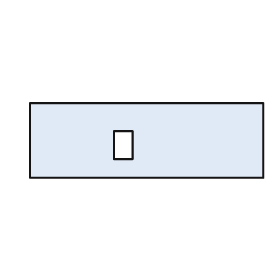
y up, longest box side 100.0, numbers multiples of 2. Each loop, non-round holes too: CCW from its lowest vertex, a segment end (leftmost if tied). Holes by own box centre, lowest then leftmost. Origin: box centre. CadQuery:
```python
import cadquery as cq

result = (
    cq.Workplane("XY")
    .moveTo(-50.0, -16.0)
    .lineTo(50.0, -16.0)
    .lineTo(50.0, 16.0)
    .lineTo(-50.0, 16.0)
    .close()
    .moveTo(-14.0, -8.0)
    .lineTo(-6.0, -8.0)
    .lineTo(-6.0, 4.0)
    .lineTo(-14.0, 4.0)
    .close()
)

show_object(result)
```